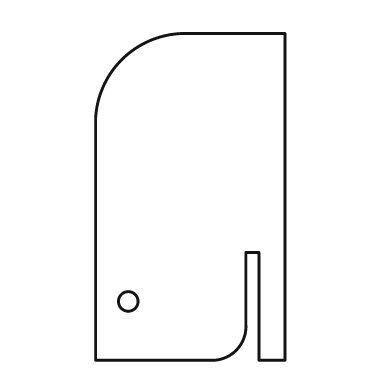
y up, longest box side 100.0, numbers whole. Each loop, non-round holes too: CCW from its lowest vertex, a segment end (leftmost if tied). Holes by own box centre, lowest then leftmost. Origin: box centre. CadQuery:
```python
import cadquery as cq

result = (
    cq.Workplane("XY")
    .moveTo(-29.0, -50.0)
    .lineTo(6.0, -50.0)
    .threePointArc((14.0, -47.0), (17.0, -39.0))
    .lineTo(17.0, -17.0)
    .lineTo(21.0, -17.0)
    .lineTo(21.0, -50.0)
    .lineTo(29.0, -50.0)
    .lineTo(29.0, 50.0)
    .lineTo(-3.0, 50.0)
    .threePointArc((-21.0, 42.0), (-29.0, 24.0))
    .close()
    .moveTo(-19.0, -32.0)
    .circle(3.0)
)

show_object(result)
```